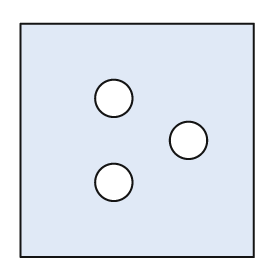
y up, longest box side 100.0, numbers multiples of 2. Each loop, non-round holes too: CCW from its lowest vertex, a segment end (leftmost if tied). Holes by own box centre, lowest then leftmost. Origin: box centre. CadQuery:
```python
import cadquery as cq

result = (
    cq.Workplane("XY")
    .moveTo(-50.0, -50.0)
    .lineTo(50.0, -50.0)
    .lineTo(50.0, 50.0)
    .lineTo(-50.0, 50.0)
    .close()
    .moveTo(-10.0, -18.0)
    .circle(8.0)
    .moveTo(22.0, 0.0)
    .circle(8.0)
    .moveTo(-10.0, 18.0)
    .circle(8.0)
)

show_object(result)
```